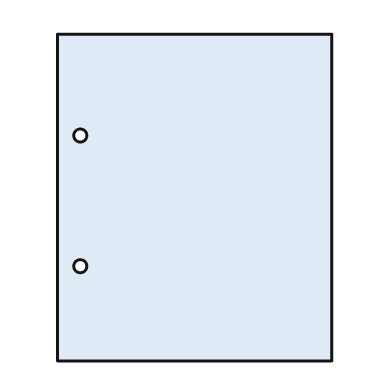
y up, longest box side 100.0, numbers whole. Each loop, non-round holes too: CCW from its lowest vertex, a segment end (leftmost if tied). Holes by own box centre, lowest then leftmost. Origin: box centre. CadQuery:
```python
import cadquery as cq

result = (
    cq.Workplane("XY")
    .moveTo(-42.0, -50.0)
    .lineTo(42.0, -50.0)
    .lineTo(42.0, 50.0)
    .lineTo(-42.0, 50.0)
    .close()
    .moveTo(-35.0, -21.0)
    .circle(2.0)
    .moveTo(-35.0, 19.0)
    .circle(2.0)
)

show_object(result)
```